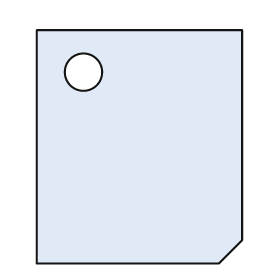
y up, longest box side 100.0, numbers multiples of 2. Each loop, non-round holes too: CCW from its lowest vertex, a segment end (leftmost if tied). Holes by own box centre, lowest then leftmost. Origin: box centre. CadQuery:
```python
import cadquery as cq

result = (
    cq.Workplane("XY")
    .moveTo(-44.0, -50.0)
    .lineTo(34.0, -50.0)
    .lineTo(44.0, -40.0)
    .lineTo(44.0, 50.0)
    .lineTo(-44.0, 50.0)
    .close()
    .moveTo(-24.0, 32.0)
    .circle(8.0)
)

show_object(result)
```